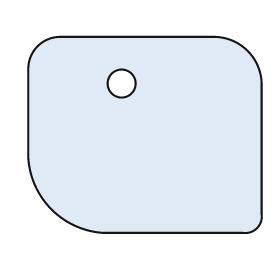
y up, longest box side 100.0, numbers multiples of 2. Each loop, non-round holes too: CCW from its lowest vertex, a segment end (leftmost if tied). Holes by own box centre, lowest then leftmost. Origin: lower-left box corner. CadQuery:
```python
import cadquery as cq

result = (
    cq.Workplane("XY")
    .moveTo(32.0, 0.0)
    .lineTo(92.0, 0.0)
    .threePointArc((98.0, 2.0), (100.0, 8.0))
    .lineTo(100.0, 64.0)
    .threePointArc((94.0, 78.0), (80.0, 84.0))
    .lineTo(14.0, 84.0)
    .threePointArc((4.0, 80.0), (0.0, 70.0))
    .lineTo(0.0, 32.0)
    .threePointArc((10.0, 10.0), (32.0, 0.0))
    .close()
    .moveTo(40.0, 64.0)
    .circle(6.0)
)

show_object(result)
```